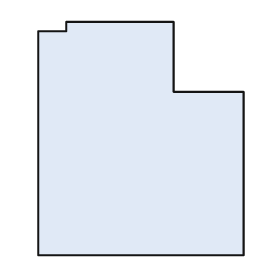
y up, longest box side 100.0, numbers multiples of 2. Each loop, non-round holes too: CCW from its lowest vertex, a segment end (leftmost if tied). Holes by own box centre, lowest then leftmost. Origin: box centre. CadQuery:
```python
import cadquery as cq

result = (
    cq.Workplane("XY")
    .moveTo(-44.0, -50.0)
    .lineTo(44.0, -50.0)
    .lineTo(44.0, 20.0)
    .lineTo(14.0, 20.0)
    .lineTo(14.0, 50.0)
    .lineTo(-32.0, 50.0)
    .lineTo(-32.0, 46.0)
    .lineTo(-44.0, 46.0)
    .close()
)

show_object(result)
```